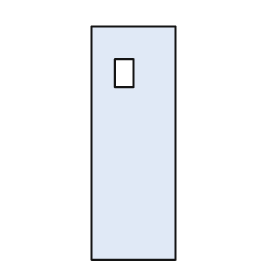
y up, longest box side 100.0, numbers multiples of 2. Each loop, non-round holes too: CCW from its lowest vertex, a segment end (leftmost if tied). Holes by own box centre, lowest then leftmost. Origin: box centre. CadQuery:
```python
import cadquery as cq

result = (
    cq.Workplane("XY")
    .moveTo(-18.0, -50.0)
    .lineTo(18.0, -50.0)
    .lineTo(18.0, 50.0)
    .lineTo(-18.0, 50.0)
    .close()
    .moveTo(-8.0, 24.0)
    .lineTo(0.0, 24.0)
    .lineTo(0.0, 36.0)
    .lineTo(-8.0, 36.0)
    .close()
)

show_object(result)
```